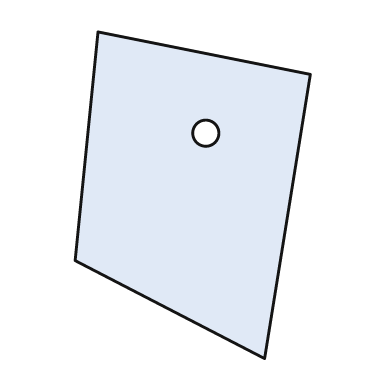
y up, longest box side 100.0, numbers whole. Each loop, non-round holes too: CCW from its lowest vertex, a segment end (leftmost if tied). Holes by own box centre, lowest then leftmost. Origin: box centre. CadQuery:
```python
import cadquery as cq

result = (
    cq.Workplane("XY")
    .moveTo(22.0, -50.0)
    .lineTo(36.0, 37.0)
    .lineTo(-29.0, 50.0)
    .lineTo(-36.0, -20.0)
    .close()
    .moveTo(4.0, 19.0)
    .circle(4.0)
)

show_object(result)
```